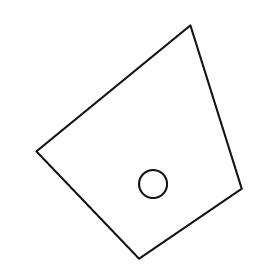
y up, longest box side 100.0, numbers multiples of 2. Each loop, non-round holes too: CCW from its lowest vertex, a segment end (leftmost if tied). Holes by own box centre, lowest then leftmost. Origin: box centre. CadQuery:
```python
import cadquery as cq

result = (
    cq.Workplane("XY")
    .moveTo(0.0, -50.0)
    .lineTo(44.0, -20.0)
    .lineTo(22.0, 50.0)
    .lineTo(-44.0, -4.0)
    .close()
    .moveTo(6.0, -18.0)
    .circle(6.0)
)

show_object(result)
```